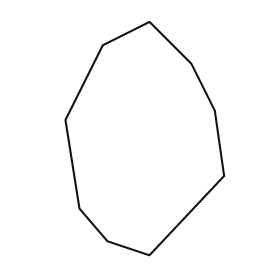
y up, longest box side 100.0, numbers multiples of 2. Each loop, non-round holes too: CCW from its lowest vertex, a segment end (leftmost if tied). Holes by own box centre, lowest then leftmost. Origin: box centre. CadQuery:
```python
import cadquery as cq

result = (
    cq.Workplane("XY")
    .moveTo(2.0, -50.0)
    .lineTo(34.0, -16.0)
    .lineTo(30.0, 12.0)
    .lineTo(20.0, 32.0)
    .lineTo(2.0, 50.0)
    .lineTo(-18.0, 40.0)
    .lineTo(-34.0, 8.0)
    .lineTo(-28.0, -30.0)
    .lineTo(-16.0, -44.0)
    .close()
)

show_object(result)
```